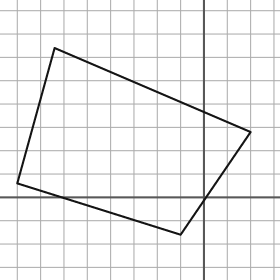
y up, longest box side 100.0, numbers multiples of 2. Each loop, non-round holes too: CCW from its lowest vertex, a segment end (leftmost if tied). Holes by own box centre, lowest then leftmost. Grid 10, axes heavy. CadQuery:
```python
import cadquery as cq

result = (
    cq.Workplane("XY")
    .moveTo(-10.0, -16.0)
    .lineTo(20.0, 28.0)
    .lineTo(-64.0, 64.0)
    .lineTo(-80.0, 6.0)
    .close()
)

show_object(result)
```